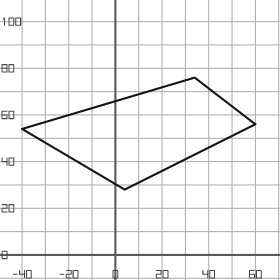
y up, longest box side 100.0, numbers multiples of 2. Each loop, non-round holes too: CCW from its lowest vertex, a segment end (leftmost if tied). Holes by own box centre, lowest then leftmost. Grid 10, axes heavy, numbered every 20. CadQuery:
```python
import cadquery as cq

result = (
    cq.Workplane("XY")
    .moveTo(4.0, 28.0)
    .lineTo(60.0, 56.0)
    .lineTo(34.0, 76.0)
    .lineTo(-40.0, 54.0)
    .close()
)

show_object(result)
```